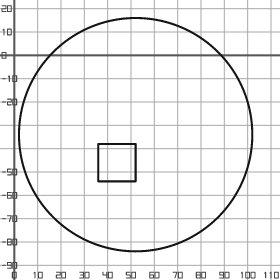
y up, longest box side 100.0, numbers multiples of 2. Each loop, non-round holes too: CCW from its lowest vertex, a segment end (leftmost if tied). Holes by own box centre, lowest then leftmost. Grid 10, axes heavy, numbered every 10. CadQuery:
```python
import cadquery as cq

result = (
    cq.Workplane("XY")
    .moveTo(52.0, -34.0)
    .circle(50.0)
    .moveTo(36.0, -54.0)
    .lineTo(52.0, -54.0)
    .lineTo(52.0, -38.0)
    .lineTo(36.0, -38.0)
    .close()
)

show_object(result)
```